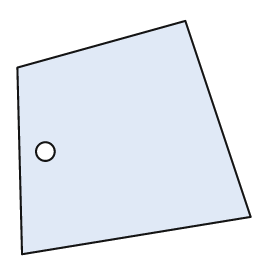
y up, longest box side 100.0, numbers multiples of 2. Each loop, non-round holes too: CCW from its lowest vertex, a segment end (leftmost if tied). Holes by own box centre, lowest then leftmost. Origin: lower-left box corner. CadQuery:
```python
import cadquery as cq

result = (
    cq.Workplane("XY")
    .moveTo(2.0, 0.0)
    .lineTo(100.0, 16.0)
    .lineTo(72.0, 100.0)
    .lineTo(0.0, 80.0)
    .close()
    .moveTo(12.0, 44.0)
    .circle(4.0)
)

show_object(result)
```